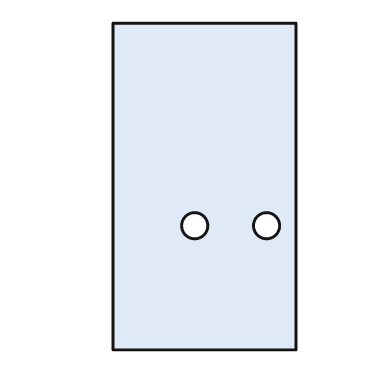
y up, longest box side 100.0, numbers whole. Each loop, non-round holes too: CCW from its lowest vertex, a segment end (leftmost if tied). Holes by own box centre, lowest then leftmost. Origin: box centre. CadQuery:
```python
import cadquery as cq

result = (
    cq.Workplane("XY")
    .moveTo(-28.0, -50.0)
    .lineTo(28.0, -50.0)
    .lineTo(28.0, 50.0)
    .lineTo(-28.0, 50.0)
    .close()
    .moveTo(-3.0, -12.0)
    .circle(4.0)
    .moveTo(19.0, -12.0)
    .circle(4.0)
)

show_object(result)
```